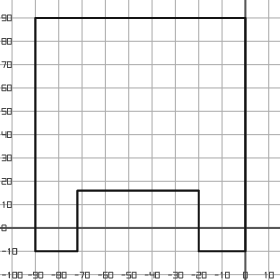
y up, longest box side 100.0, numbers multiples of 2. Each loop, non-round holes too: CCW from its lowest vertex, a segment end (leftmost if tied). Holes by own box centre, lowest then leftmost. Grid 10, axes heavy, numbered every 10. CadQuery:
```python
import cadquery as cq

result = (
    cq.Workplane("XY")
    .moveTo(-90.0, -10.0)
    .lineTo(-72.0, -10.0)
    .lineTo(-72.0, 16.0)
    .lineTo(-20.0, 16.0)
    .lineTo(-20.0, -10.0)
    .lineTo(0.0, -10.0)
    .lineTo(0.0, 90.0)
    .lineTo(-90.0, 90.0)
    .close()
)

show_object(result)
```